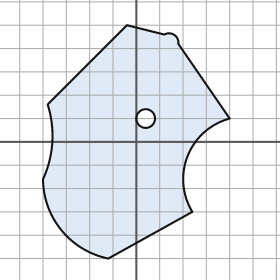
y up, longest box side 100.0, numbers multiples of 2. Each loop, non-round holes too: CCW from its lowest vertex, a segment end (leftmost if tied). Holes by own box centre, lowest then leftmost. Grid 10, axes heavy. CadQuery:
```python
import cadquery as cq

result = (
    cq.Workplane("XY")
    .moveTo(-12.0, -50.0)
    .lineTo(24.0, -30.0)
    .threePointArc((22.0, -6.0), (40.0, 10.0))
    .lineTo(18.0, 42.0)
    .threePointArc((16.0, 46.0), (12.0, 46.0))
    .lineTo(-4.0, 50.0)
    .lineTo(-38.0, 16.0)
    .threePointArc((-36.0, 0.0), (-40.0, -16.0))
    .threePointArc((-32.0, -38.0), (-12.0, -50.0))
    .close()
    .moveTo(4.0, 10.0)
    .circle(4.0)
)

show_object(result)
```